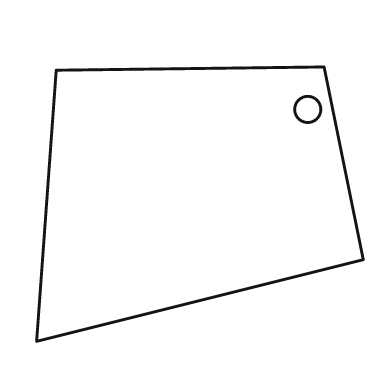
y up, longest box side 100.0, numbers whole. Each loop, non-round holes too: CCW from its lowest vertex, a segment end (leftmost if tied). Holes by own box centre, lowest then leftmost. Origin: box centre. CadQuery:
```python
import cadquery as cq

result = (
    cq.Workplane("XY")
    .moveTo(-50.0, -42.0)
    .lineTo(50.0, -17.0)
    .lineTo(38.0, 42.0)
    .lineTo(-44.0, 41.0)
    .close()
    .moveTo(33.0, 29.0)
    .circle(4.0)
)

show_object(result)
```